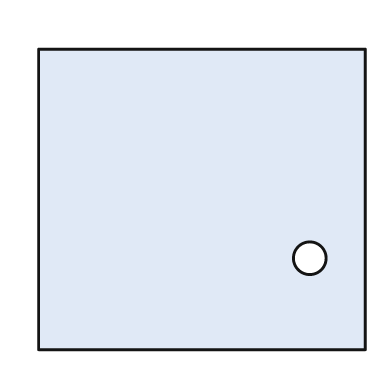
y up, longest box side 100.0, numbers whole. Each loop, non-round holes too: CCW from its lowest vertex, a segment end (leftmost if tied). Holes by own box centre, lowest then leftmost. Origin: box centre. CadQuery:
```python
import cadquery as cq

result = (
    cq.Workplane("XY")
    .moveTo(-50.0, -46.0)
    .lineTo(50.0, -46.0)
    .lineTo(50.0, 46.0)
    .lineTo(-50.0, 46.0)
    .close()
    .moveTo(33.0, -18.0)
    .circle(5.0)
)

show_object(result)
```